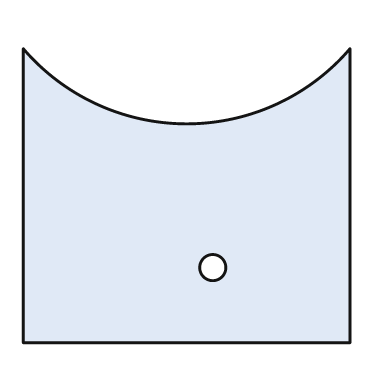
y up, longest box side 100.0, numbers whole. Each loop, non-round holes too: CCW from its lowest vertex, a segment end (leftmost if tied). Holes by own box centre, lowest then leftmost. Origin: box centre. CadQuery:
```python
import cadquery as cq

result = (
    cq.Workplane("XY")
    .moveTo(-50.0, -45.0)
    .lineTo(50.0, -45.0)
    .lineTo(50.0, 45.0)
    .threePointArc((0.0, 22.0), (-50.0, 45.0))
    .close()
    .moveTo(8.0, -22.0)
    .circle(4.0)
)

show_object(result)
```